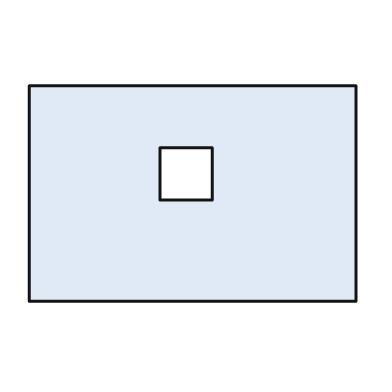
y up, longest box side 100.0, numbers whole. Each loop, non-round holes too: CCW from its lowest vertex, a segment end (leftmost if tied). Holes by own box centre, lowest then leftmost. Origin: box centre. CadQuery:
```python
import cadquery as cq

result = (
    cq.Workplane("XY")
    .moveTo(-50.0, -33.0)
    .lineTo(50.0, -33.0)
    .lineTo(50.0, 33.0)
    .lineTo(-50.0, 33.0)
    .close()
    .moveTo(-10.0, -2.0)
    .lineTo(6.0, -2.0)
    .lineTo(6.0, 14.0)
    .lineTo(-10.0, 14.0)
    .close()
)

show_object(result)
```